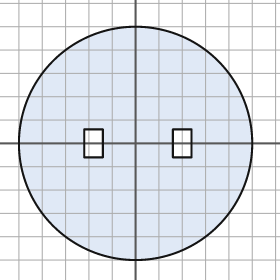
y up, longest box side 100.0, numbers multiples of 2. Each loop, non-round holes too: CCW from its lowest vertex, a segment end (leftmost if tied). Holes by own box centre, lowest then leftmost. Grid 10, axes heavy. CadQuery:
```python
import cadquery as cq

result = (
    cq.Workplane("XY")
    .moveTo(0.0, 0.0)
    .circle(50.0)
    .moveTo(-22.0, -6.0)
    .lineTo(-14.0, -6.0)
    .lineTo(-14.0, 6.0)
    .lineTo(-22.0, 6.0)
    .close()
    .moveTo(16.0, -6.0)
    .lineTo(24.0, -6.0)
    .lineTo(24.0, 6.0)
    .lineTo(16.0, 6.0)
    .close()
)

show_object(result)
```